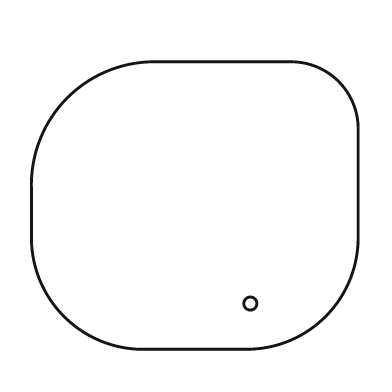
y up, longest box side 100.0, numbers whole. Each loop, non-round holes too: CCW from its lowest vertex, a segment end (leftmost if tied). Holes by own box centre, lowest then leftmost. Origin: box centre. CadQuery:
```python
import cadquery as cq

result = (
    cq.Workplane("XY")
    .moveTo(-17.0, -44.0)
    .lineTo(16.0, -44.0)
    .threePointArc((40.0, -34.0), (50.0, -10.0))
    .lineTo(50.0, 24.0)
    .threePointArc((44.0, 38.0), (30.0, 44.0))
    .lineTo(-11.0, 44.0)
    .threePointArc((-39.0, 33.0), (-50.0, 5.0))
    .lineTo(-50.0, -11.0)
    .threePointArc((-40.0, -34.0), (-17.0, -44.0))
    .close()
    .moveTo(17.0, -30.0)
    .circle(2.0)
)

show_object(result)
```